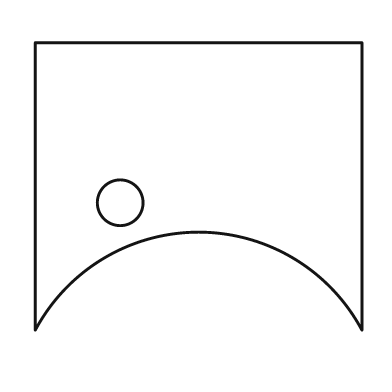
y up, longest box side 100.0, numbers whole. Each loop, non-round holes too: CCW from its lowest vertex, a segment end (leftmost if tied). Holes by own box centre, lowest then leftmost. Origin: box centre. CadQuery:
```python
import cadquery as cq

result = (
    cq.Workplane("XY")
    .moveTo(-50.0, -44.0)
    .threePointArc((0.0, -14.0), (50.0, -44.0))
    .lineTo(50.0, 44.0)
    .lineTo(-50.0, 44.0)
    .close()
    .moveTo(-24.0, -5.0)
    .circle(7.0)
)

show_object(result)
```